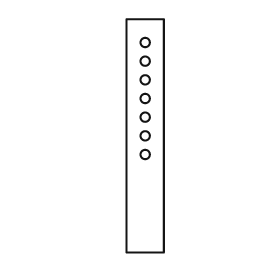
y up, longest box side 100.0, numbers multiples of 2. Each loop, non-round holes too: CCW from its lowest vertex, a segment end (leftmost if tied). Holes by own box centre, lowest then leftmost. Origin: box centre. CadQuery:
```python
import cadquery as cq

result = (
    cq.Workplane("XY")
    .moveTo(-8.0, -50.0)
    .lineTo(8.0, -50.0)
    .lineTo(8.0, 50.0)
    .lineTo(-8.0, 50.0)
    .close()
    .moveTo(0.0, -8.0)
    .circle(2.0)
    .moveTo(0.0, 0.0)
    .circle(2.0)
    .moveTo(0.0, 8.0)
    .circle(2.0)
    .moveTo(0.0, 16.0)
    .circle(2.0)
    .moveTo(0.0, 24.0)
    .circle(2.0)
    .moveTo(0.0, 32.0)
    .circle(2.0)
    .moveTo(0.0, 40.0)
    .circle(2.0)
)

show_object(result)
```